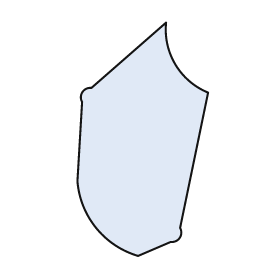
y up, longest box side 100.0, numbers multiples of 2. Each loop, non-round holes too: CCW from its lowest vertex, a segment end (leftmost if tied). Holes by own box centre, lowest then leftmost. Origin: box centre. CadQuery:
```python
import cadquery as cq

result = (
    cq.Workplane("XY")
    .moveTo(-2.0, -50.0)
    .lineTo(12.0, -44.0)
    .threePointArc((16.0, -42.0), (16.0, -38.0))
    .lineTo(28.0, 20.0)
    .threePointArc((14.0, 32.0), (10.0, 50.0))
    .lineTo(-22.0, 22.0)
    .threePointArc((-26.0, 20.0), (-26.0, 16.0))
    .lineTo(-28.0, -18.0)
    .threePointArc((-20.0, -38.0), (-2.0, -50.0))
    .close()
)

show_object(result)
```